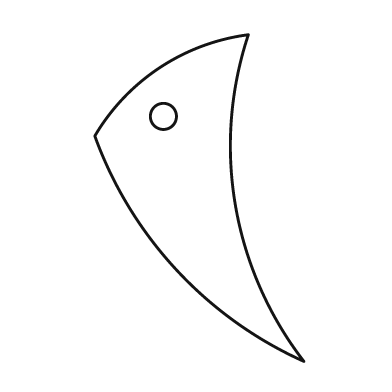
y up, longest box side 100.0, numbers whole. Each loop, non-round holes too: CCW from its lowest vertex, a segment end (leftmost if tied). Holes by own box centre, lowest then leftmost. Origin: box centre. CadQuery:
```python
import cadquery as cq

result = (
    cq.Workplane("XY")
    .moveTo(32.0, -50.0)
    .threePointArc((11.0, -2.0), (15.0, 50.0))
    .threePointArc((-12.0, 40.0), (-32.0, 19.0))
    .threePointArc((-7.0, -22.0), (32.0, -50.0))
    .close()
    .moveTo(-11.0, 25.0)
    .circle(4.0)
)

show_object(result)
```